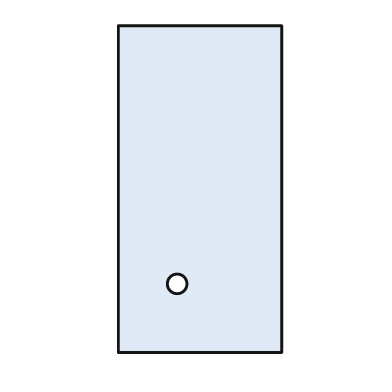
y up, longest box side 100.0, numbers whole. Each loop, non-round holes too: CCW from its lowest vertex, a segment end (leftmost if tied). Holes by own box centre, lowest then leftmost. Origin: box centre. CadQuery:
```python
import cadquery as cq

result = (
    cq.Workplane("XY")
    .moveTo(-25.0, -50.0)
    .lineTo(25.0, -50.0)
    .lineTo(25.0, 50.0)
    .lineTo(-25.0, 50.0)
    .close()
    .moveTo(-7.0, -29.0)
    .circle(3.0)
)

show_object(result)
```